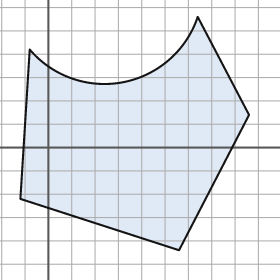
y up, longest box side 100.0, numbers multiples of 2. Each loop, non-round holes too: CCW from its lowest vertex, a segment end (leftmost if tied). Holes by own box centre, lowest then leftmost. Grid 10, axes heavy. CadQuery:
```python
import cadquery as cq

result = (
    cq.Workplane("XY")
    .moveTo(56.0, -44.0)
    .lineTo(86.0, 14.0)
    .lineTo(64.0, 56.0)
    .threePointArc((32.0, 28.0), (-8.0, 42.0))
    .lineTo(-12.0, -22.0)
    .close()
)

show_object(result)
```